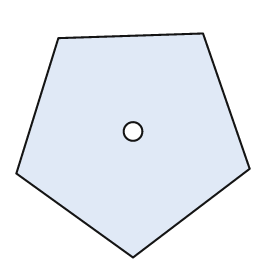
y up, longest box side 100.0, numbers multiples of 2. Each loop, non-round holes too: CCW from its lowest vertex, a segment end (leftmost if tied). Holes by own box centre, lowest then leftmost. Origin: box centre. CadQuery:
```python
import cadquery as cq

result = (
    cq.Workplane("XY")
    .moveTo(0.0, -48.0)
    .lineTo(50.0, -10.0)
    .lineTo(30.0, 48.0)
    .lineTo(-32.0, 46.0)
    .lineTo(-50.0, -12.0)
    .close()
    .moveTo(0.0, 6.0)
    .circle(4.0)
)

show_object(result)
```